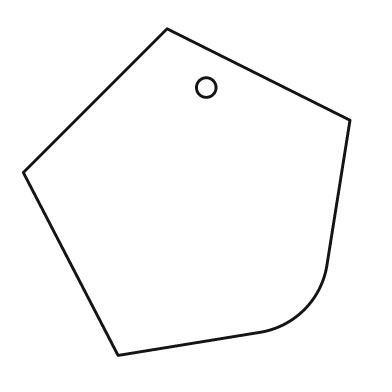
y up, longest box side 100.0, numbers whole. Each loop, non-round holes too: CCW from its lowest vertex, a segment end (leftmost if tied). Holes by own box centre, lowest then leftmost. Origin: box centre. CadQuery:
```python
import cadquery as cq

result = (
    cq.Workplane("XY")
    .moveTo(-21.0, -50.0)
    .lineTo(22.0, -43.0)
    .threePointArc((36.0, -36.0), (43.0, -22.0))
    .lineTo(50.0, 22.0)
    .lineTo(-6.0, 50.0)
    .lineTo(-50.0, 6.0)
    .close()
    .moveTo(6.0, 32.0)
    .circle(3.0)
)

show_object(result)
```